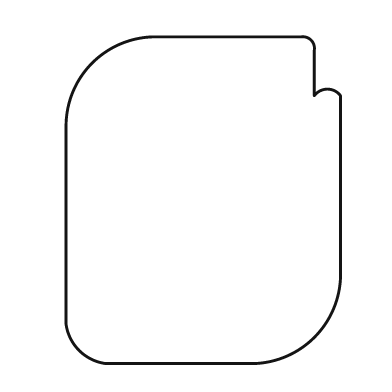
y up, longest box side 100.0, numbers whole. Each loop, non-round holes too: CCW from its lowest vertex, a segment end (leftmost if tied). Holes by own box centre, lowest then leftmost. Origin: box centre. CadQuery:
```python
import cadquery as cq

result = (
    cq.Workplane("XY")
    .moveTo(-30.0, -50.0)
    .lineTo(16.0, -50.0)
    .threePointArc((34.0, -42.0), (42.0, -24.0))
    .lineTo(42.0, 32.0)
    .threePointArc((38.0, 34.0), (34.0, 32.0))
    .lineTo(34.0, 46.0)
    .threePointArc((33.0, 49.0), (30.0, 50.0))
    .lineTo(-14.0, 50.0)
    .threePointArc((-34.0, 42.0), (-42.0, 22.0))
    .lineTo(-42.0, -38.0)
    .threePointArc((-38.0, -46.0), (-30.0, -50.0))
    .close()
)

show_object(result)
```